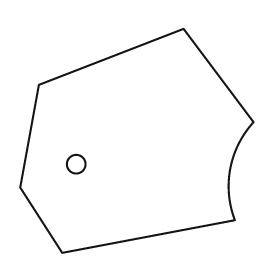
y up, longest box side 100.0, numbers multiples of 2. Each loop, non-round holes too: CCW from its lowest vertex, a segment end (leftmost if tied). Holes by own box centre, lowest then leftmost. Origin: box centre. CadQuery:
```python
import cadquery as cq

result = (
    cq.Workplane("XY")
    .moveTo(-32.0, -48.0)
    .lineTo(42.0, -34.0)
    .threePointArc((40.0, -12.0), (50.0, 8.0))
    .lineTo(20.0, 48.0)
    .lineTo(-42.0, 24.0)
    .lineTo(-50.0, -20.0)
    .close()
    .moveTo(-26.0, -10.0)
    .circle(4.0)
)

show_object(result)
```